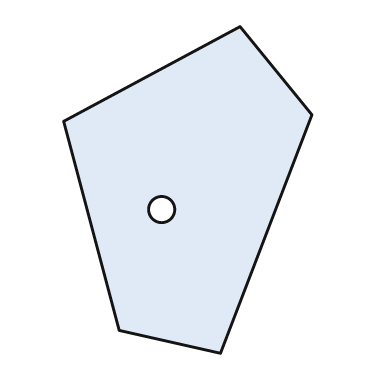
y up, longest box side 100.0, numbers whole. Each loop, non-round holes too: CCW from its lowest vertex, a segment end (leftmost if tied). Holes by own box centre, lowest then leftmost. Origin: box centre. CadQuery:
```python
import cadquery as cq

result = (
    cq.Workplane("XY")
    .moveTo(10.0, -50.0)
    .lineTo(38.0, 23.0)
    .lineTo(16.0, 50.0)
    .lineTo(-38.0, 21.0)
    .lineTo(-21.0, -43.0)
    .close()
    .moveTo(-8.0, -6.0)
    .circle(4.0)
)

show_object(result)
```